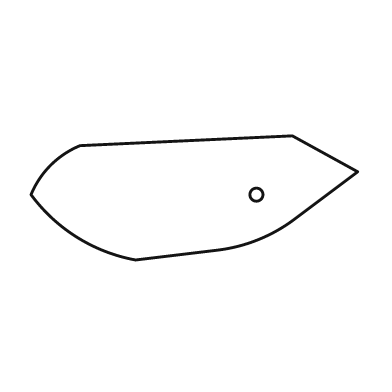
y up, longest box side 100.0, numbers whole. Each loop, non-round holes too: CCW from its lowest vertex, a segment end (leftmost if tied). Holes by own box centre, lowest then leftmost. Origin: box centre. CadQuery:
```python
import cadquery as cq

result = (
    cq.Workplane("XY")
    .moveTo(-18.0, -19.0)
    .lineTo(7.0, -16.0)
    .threePointArc((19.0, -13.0), (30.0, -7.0))
    .lineTo(50.0, 8.0)
    .lineTo(30.0, 19.0)
    .lineTo(-35.0, 16.0)
    .threePointArc((-44.0, 10.0), (-50.0, 1.0))
    .threePointArc((-36.0, -12.0), (-18.0, -19.0))
    .close()
    .moveTo(19.0, 1.0)
    .circle(2.0)
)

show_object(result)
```